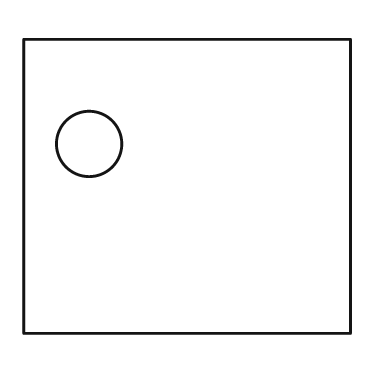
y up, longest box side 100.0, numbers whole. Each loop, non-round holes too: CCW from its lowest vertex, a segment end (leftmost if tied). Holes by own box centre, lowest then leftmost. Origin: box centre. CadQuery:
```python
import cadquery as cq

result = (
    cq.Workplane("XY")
    .moveTo(-50.0, -45.0)
    .lineTo(50.0, -45.0)
    .lineTo(50.0, 45.0)
    .lineTo(-50.0, 45.0)
    .close()
    .moveTo(-30.0, 13.0)
    .circle(10.0)
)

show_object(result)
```